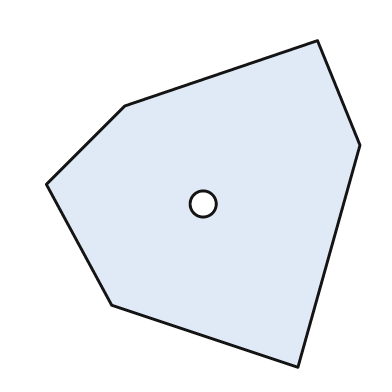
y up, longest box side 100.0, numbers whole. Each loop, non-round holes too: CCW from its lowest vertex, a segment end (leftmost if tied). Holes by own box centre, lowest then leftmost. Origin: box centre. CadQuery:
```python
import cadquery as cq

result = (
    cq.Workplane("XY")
    .moveTo(29.0, -50.0)
    .lineTo(48.0, 18.0)
    .lineTo(35.0, 50.0)
    .lineTo(-24.0, 30.0)
    .lineTo(-48.0, 6.0)
    .lineTo(-28.0, -31.0)
    .close()
    .moveTo(0.0, 0.0)
    .circle(4.0)
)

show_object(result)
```